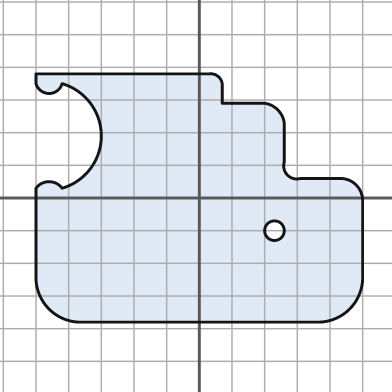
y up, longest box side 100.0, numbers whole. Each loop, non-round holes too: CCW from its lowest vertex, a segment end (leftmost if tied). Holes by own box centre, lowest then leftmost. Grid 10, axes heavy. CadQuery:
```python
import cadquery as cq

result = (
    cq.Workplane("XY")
    .moveTo(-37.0, -38.0)
    .lineTo(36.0, -38.0)
    .threePointArc((46.0, -34.0), (50.0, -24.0))
    .lineTo(50.0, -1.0)
    .threePointArc((48.0, 4.0), (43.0, 6.0))
    .lineTo(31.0, 6.0)
    .threePointArc((27.0, 7.0), (26.0, 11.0))
    .lineTo(26.0, 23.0)
    .threePointArc((24.0, 27.0), (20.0, 29.0))
    .lineTo(7.0, 29.0)
    .lineTo(7.0, 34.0)
    .threePointArc((6.0, 37.0), (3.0, 38.0))
    .lineTo(-50.0, 38.0)
    .lineTo(-50.0, 35.0)
    .threePointArc((-46.0, 32.0), (-42.0, 35.0))
    .threePointArc((-30.0, 19.0), (-42.0, 3.0))
    .threePointArc((-46.0, 5.0), (-50.0, 3.0))
    .lineTo(-50.0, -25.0)
    .threePointArc((-46.0, -34.0), (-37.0, -38.0))
    .close()
    .moveTo(23.0, -10.0)
    .circle(3.0)
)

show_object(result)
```